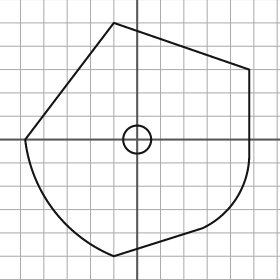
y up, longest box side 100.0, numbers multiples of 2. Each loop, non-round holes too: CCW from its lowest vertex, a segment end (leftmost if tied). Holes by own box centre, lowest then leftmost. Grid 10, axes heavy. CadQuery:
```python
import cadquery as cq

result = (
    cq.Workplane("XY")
    .moveTo(-10.0, -50.0)
    .lineTo(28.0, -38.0)
    .threePointArc((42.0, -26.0), (48.0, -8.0))
    .lineTo(48.0, 30.0)
    .lineTo(-10.0, 50.0)
    .lineTo(-48.0, 0.0)
    .threePointArc((-36.0, -30.0), (-10.0, -50.0))
    .close()
    .moveTo(0.0, 0.0)
    .circle(6.0)
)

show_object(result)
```